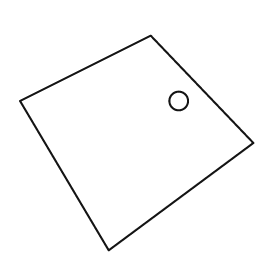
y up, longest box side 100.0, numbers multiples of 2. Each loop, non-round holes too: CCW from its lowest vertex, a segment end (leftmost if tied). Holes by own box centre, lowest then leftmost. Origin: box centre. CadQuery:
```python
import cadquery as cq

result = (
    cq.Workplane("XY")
    .moveTo(-12.0, -46.0)
    .lineTo(50.0, 0.0)
    .lineTo(6.0, 46.0)
    .lineTo(-50.0, 18.0)
    .close()
    .moveTo(18.0, 18.0)
    .circle(4.0)
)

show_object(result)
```